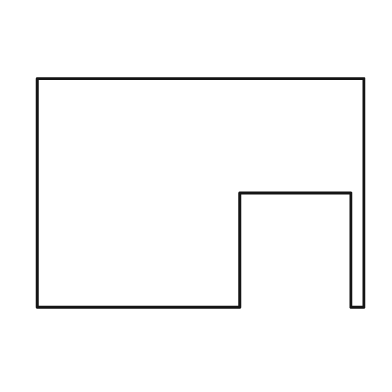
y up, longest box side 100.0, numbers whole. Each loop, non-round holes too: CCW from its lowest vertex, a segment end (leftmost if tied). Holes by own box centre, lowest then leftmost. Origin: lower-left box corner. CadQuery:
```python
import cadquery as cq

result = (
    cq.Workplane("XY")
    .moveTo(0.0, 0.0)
    .lineTo(62.0, 0.0)
    .lineTo(62.0, 35.0)
    .lineTo(96.0, 35.0)
    .lineTo(96.0, 0.0)
    .lineTo(100.0, 0.0)
    .lineTo(100.0, 70.0)
    .lineTo(0.0, 70.0)
    .close()
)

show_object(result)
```